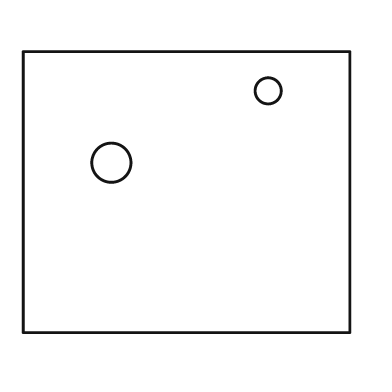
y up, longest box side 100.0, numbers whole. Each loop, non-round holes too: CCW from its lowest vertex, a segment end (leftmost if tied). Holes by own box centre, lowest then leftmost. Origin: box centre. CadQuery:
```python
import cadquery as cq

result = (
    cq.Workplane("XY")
    .moveTo(-50.0, -43.0)
    .lineTo(50.0, -43.0)
    .lineTo(50.0, 43.0)
    .lineTo(-50.0, 43.0)
    .close()
    .moveTo(-23.0, 9.0)
    .circle(6.0)
    .moveTo(25.0, 31.0)
    .circle(4.0)
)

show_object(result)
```